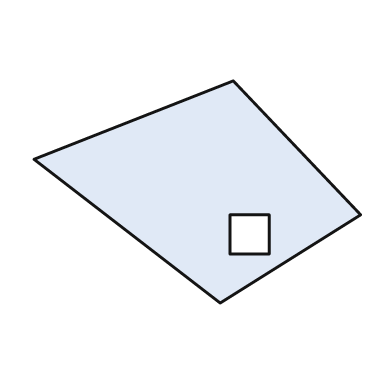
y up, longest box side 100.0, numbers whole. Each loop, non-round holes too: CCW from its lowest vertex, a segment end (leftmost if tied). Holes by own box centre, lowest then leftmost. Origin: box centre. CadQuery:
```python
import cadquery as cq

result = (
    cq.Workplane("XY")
    .moveTo(7.0, -34.0)
    .lineTo(50.0, -7.0)
    .lineTo(11.0, 34.0)
    .lineTo(-50.0, 10.0)
    .close()
    .moveTo(10.0, -19.0)
    .lineTo(22.0, -19.0)
    .lineTo(22.0, -7.0)
    .lineTo(10.0, -7.0)
    .close()
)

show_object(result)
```